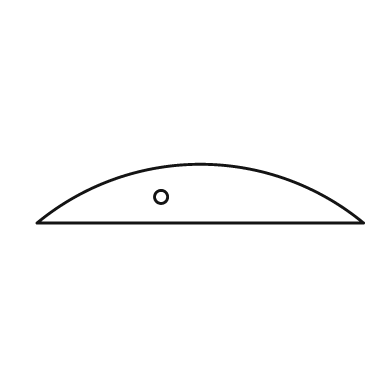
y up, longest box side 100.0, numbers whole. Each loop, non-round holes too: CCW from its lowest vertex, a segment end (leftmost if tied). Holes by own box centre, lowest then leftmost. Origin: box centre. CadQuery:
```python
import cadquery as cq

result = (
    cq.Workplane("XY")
    .moveTo(-50.0, -9.0)
    .lineTo(50.0, -9.0)
    .threePointArc((0.0, 9.0), (-50.0, -9.0))
    .close()
    .moveTo(-12.0, -1.0)
    .circle(2.0)
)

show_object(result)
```